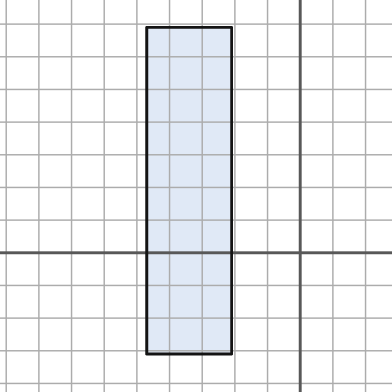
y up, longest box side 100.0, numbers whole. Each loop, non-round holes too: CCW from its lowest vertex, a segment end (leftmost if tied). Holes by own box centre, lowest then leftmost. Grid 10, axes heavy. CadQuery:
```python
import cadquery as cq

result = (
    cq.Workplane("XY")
    .moveTo(-47.0, -31.0)
    .lineTo(-21.0, -31.0)
    .lineTo(-21.0, 69.0)
    .lineTo(-47.0, 69.0)
    .close()
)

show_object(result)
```